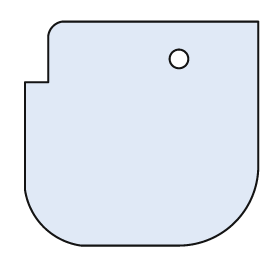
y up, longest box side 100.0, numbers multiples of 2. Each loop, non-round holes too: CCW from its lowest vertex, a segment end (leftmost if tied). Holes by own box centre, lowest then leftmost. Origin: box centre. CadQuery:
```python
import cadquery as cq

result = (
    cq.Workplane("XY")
    .moveTo(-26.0, -48.0)
    .lineTo(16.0, -48.0)
    .threePointArc((40.0, -38.0), (50.0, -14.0))
    .lineTo(50.0, 48.0)
    .lineTo(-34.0, 48.0)
    .threePointArc((-38.0, 46.0), (-40.0, 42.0))
    .lineTo(-40.0, 22.0)
    .lineTo(-50.0, 22.0)
    .lineTo(-50.0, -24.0)
    .threePointArc((-42.0, -40.0), (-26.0, -48.0))
    .close()
    .moveTo(16.0, 32.0)
    .circle(4.0)
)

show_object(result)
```